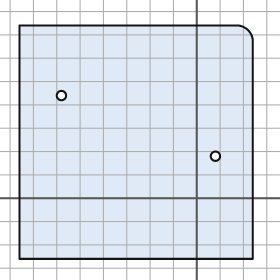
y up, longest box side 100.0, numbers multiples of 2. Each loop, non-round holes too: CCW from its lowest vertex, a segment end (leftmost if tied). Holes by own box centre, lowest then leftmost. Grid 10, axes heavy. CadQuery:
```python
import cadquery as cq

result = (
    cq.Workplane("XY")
    .moveTo(-76.0, -26.0)
    .lineTo(24.0, -26.0)
    .lineTo(24.0, 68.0)
    .threePointArc((22.0, 72.0), (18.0, 74.0))
    .lineTo(-76.0, 74.0)
    .close()
    .moveTo(8.0, 18.0)
    .circle(2.0)
    .moveTo(-58.0, 44.0)
    .circle(2.0)
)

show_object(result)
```